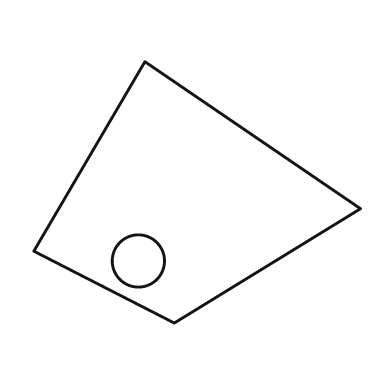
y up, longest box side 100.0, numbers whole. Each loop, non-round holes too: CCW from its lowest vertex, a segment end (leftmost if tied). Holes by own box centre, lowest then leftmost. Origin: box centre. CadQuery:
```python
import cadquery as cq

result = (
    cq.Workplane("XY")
    .moveTo(-7.0, -40.0)
    .lineTo(50.0, -5.0)
    .lineTo(-16.0, 40.0)
    .lineTo(-50.0, -18.0)
    .close()
    .moveTo(-18.0, -21.0)
    .circle(8.0)
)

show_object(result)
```